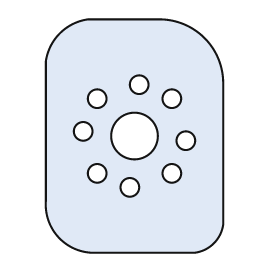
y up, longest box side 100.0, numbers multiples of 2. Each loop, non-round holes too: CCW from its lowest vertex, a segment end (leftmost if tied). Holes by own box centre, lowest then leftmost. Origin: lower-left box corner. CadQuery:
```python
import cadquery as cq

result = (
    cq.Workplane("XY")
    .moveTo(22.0, 0.0)
    .lineTo(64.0, 0.0)
    .threePointArc((72.0, 4.0), (76.0, 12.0))
    .lineTo(76.0, 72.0)
    .threePointArc((68.0, 92.0), (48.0, 100.0))
    .lineTo(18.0, 100.0)
    .threePointArc((6.0, 94.0), (0.0, 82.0))
    .lineTo(0.0, 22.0)
    .threePointArc((6.0, 6.0), (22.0, 0.0))
    .close()
    .moveTo(36.0, 28.0)
    .circle(4.0)
    .moveTo(22.0, 34.0)
    .circle(4.0)
    .moveTo(54.0, 34.0)
    .circle(4.0)
    .moveTo(60.0, 48.0)
    .circle(4.0)
    .moveTo(38.0, 50.0)
    .circle(10.0)
    .moveTo(16.0, 52.0)
    .circle(4.0)
    .moveTo(22.0, 66.0)
    .circle(4.0)
    .moveTo(54.0, 66.0)
    .circle(4.0)
    .moveTo(40.0, 72.0)
    .circle(4.0)
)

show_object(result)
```